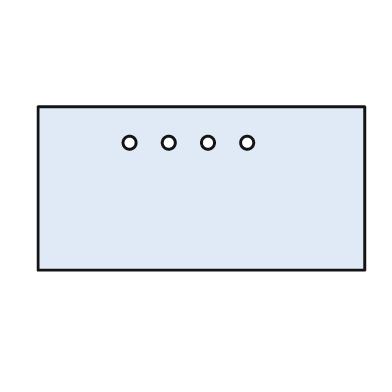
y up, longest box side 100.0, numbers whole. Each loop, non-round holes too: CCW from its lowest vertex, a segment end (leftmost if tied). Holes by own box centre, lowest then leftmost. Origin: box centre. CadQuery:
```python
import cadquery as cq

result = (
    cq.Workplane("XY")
    .moveTo(-50.0, -25.0)
    .lineTo(50.0, -25.0)
    .lineTo(50.0, 25.0)
    .lineTo(-50.0, 25.0)
    .close()
    .moveTo(-22.0, 14.0)
    .circle(2.0)
    .moveTo(-10.0, 14.0)
    .circle(2.0)
    .moveTo(2.0, 14.0)
    .circle(2.0)
    .moveTo(14.0, 14.0)
    .circle(2.0)
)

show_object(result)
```